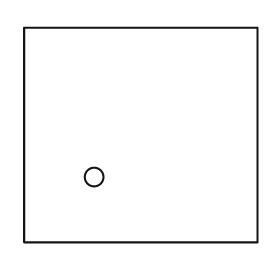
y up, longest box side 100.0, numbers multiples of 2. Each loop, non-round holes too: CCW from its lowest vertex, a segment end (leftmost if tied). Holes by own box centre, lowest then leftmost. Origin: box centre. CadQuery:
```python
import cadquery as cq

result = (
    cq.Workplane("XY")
    .moveTo(-50.0, -46.0)
    .lineTo(50.0, -46.0)
    .lineTo(50.0, 46.0)
    .lineTo(-50.0, 46.0)
    .close()
    .moveTo(-20.0, -18.0)
    .circle(4.0)
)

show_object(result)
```